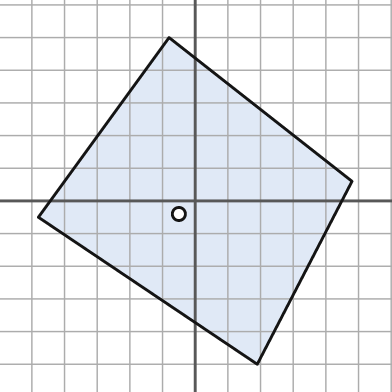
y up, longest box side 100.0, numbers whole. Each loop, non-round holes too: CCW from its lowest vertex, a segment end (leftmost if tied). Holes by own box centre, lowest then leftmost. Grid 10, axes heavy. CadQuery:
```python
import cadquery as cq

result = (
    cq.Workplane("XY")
    .moveTo(19.0, -50.0)
    .lineTo(48.0, 6.0)
    .lineTo(-8.0, 50.0)
    .lineTo(-48.0, -5.0)
    .close()
    .moveTo(-5.0, -4.0)
    .circle(2.0)
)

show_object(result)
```